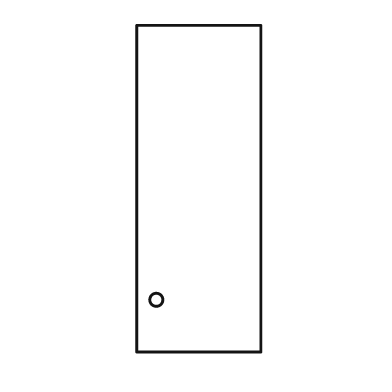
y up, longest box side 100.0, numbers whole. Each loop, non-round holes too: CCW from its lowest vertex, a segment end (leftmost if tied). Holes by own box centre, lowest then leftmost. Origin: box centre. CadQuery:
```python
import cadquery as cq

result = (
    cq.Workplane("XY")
    .moveTo(-19.0, -50.0)
    .lineTo(19.0, -50.0)
    .lineTo(19.0, 50.0)
    .lineTo(-19.0, 50.0)
    .close()
    .moveTo(-13.0, -34.0)
    .circle(2.0)
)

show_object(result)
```